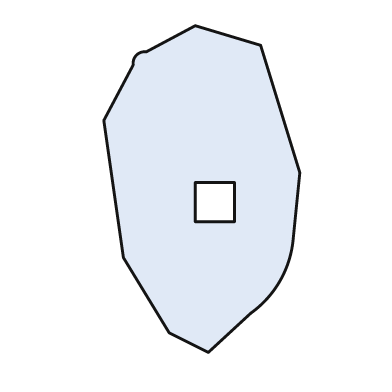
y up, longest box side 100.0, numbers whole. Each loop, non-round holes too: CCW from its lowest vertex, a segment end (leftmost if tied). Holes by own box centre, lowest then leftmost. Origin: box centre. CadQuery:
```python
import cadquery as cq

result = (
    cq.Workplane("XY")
    .moveTo(2.0, -50.0)
    .lineTo(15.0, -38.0)
    .threePointArc((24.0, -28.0), (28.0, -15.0))
    .lineTo(30.0, 5.0)
    .lineTo(18.0, 44.0)
    .lineTo(-2.0, 50.0)
    .lineTo(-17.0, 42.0)
    .threePointArc((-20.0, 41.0), (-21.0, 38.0))
    .lineTo(-30.0, 21.0)
    .lineTo(-24.0, -21.0)
    .lineTo(-10.0, -44.0)
    .close()
    .moveTo(-2.0, -10.0)
    .lineTo(10.0, -10.0)
    .lineTo(10.0, 2.0)
    .lineTo(-2.0, 2.0)
    .close()
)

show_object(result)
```